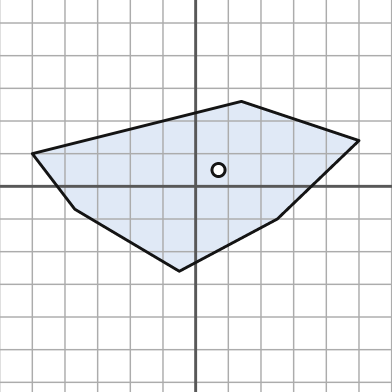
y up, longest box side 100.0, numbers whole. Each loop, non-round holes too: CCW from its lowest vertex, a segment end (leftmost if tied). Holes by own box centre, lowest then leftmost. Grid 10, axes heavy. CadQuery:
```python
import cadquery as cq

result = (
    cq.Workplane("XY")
    .moveTo(-5.0, -26.0)
    .lineTo(25.0, -10.0)
    .lineTo(50.0, 14.0)
    .lineTo(14.0, 26.0)
    .lineTo(-50.0, 10.0)
    .lineTo(-37.0, -7.0)
    .close()
    .moveTo(7.0, 5.0)
    .circle(2.0)
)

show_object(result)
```